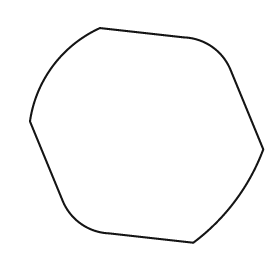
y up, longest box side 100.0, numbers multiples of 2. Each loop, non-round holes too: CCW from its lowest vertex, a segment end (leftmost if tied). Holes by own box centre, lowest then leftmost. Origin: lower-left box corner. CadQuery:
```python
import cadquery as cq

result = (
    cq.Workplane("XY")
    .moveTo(70.0, 0.0)
    .threePointArc((88.0, 18.0), (100.0, 40.0))
    .lineTo(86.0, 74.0)
    .threePointArc((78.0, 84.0), (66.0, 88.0))
    .lineTo(30.0, 92.0)
    .threePointArc((10.0, 76.0), (0.0, 52.0))
    .lineTo(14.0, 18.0)
    .threePointArc((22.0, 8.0), (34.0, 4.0))
    .close()
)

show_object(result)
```